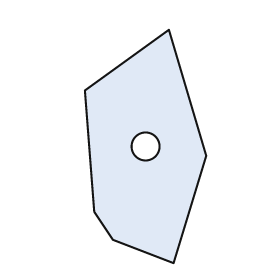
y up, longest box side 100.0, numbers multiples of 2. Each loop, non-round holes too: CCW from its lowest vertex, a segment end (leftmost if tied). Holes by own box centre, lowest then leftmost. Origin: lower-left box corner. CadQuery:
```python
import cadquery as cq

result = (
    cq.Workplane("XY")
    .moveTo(38.0, 0.0)
    .lineTo(52.0, 46.0)
    .lineTo(36.0, 100.0)
    .lineTo(0.0, 74.0)
    .lineTo(4.0, 22.0)
    .lineTo(12.0, 10.0)
    .close()
    .moveTo(26.0, 50.0)
    .circle(6.0)
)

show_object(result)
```